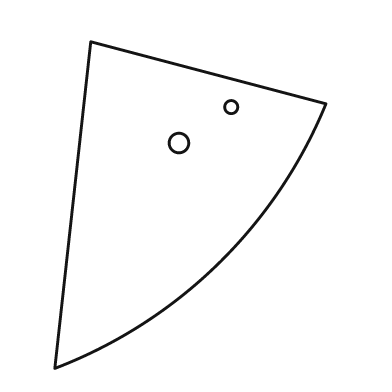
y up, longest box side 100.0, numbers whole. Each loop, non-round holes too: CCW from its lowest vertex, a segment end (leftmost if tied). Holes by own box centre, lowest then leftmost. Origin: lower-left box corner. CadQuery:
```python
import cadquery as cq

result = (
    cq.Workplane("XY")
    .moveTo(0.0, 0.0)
    .threePointArc((50.0, 32.0), (83.0, 81.0))
    .lineTo(11.0, 100.0)
    .close()
    .moveTo(38.0, 69.0)
    .circle(3.0)
    .moveTo(54.0, 80.0)
    .circle(2.0)
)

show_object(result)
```